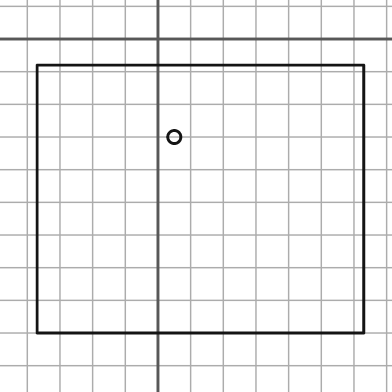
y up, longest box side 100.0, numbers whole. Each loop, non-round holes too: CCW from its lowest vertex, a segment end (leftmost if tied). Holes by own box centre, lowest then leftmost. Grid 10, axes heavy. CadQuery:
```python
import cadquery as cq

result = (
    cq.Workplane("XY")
    .moveTo(-37.0, -90.0)
    .lineTo(63.0, -90.0)
    .lineTo(63.0, -8.0)
    .lineTo(-37.0, -8.0)
    .close()
    .moveTo(5.0, -30.0)
    .circle(2.0)
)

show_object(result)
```